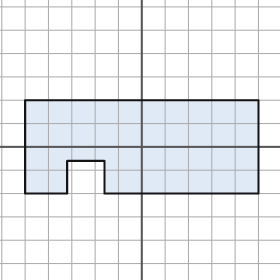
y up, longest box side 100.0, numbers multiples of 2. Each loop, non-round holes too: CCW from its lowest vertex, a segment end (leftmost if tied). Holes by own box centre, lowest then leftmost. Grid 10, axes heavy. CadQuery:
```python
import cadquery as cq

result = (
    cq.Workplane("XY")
    .moveTo(-50.0, -20.0)
    .lineTo(-32.0, -20.0)
    .lineTo(-32.0, -6.0)
    .lineTo(-16.0, -6.0)
    .lineTo(-16.0, -20.0)
    .lineTo(50.0, -20.0)
    .lineTo(50.0, 20.0)
    .lineTo(-50.0, 20.0)
    .close()
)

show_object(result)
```